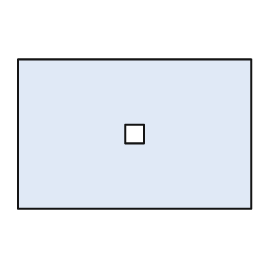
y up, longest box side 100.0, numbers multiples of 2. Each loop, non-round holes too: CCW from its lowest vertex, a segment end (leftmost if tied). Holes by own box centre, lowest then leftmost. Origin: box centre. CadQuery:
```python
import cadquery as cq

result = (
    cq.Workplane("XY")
    .moveTo(-50.0, -32.0)
    .lineTo(50.0, -32.0)
    .lineTo(50.0, 32.0)
    .lineTo(-50.0, 32.0)
    .close()
    .moveTo(-4.0, -4.0)
    .lineTo(4.0, -4.0)
    .lineTo(4.0, 4.0)
    .lineTo(-4.0, 4.0)
    .close()
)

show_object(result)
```